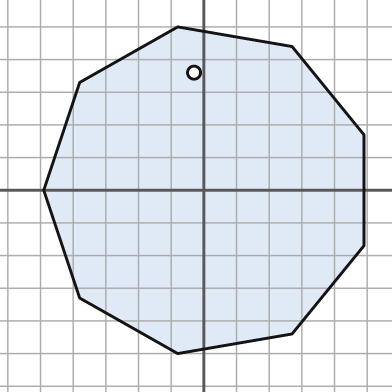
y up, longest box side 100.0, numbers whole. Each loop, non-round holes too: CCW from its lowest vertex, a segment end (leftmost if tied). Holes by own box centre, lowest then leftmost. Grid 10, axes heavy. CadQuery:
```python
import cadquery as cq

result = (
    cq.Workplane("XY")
    .moveTo(-8.0, -50.0)
    .lineTo(27.0, -44.0)
    .lineTo(49.0, -17.0)
    .lineTo(49.0, 17.0)
    .lineTo(27.0, 44.0)
    .lineTo(-8.0, 50.0)
    .lineTo(-38.0, 33.0)
    .lineTo(-49.0, 0.0)
    .lineTo(-38.0, -33.0)
    .close()
    .moveTo(-3.0, 36.0)
    .circle(2.0)
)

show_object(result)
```